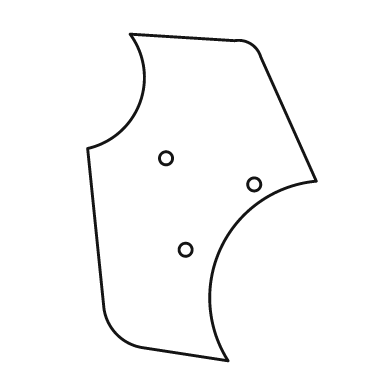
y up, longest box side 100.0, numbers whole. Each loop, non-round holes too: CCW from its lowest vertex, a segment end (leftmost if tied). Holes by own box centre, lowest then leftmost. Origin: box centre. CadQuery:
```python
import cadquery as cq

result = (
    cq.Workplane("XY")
    .moveTo(8.0, -50.0)
    .threePointArc((6.0, -15.0), (35.0, 5.0))
    .lineTo(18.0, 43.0)
    .threePointArc((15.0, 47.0), (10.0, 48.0))
    .lineTo(-22.0, 50.0)
    .threePointArc((-19.0, 29.0), (-35.0, 15.0))
    .lineTo(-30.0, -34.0)
    .threePointArc((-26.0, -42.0), (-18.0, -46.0))
    .close()
    .moveTo(-5.0, -16.0)
    .circle(2.0)
    .moveTo(16.0, 4.0)
    .circle(2.0)
    .moveTo(-11.0, 12.0)
    .circle(2.0)
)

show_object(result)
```